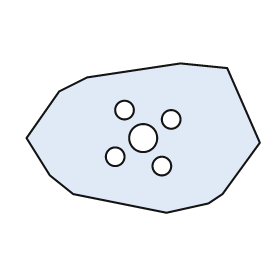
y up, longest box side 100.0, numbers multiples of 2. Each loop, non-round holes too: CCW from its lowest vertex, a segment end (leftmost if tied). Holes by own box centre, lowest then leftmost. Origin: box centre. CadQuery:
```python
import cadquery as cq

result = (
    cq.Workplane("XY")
    .moveTo(10.0, -32.0)
    .lineTo(28.0, -28.0)
    .lineTo(34.0, -24.0)
    .lineTo(50.0, -2.0)
    .lineTo(36.0, 30.0)
    .lineTo(16.0, 32.0)
    .lineTo(-24.0, 26.0)
    .lineTo(-36.0, 20.0)
    .lineTo(-50.0, 0.0)
    .lineTo(-40.0, -16.0)
    .lineTo(-30.0, -24.0)
    .close()
    .moveTo(8.0, -12.0)
    .circle(4.0)
    .moveTo(-12.0, -8.0)
    .circle(4.0)
    .moveTo(0.0, 0.0)
    .circle(6.0)
    .moveTo(12.0, 8.0)
    .circle(4.0)
    .moveTo(-8.0, 12.0)
    .circle(4.0)
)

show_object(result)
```